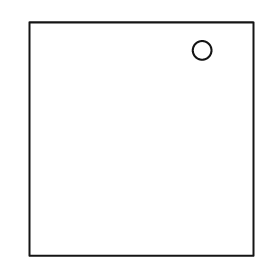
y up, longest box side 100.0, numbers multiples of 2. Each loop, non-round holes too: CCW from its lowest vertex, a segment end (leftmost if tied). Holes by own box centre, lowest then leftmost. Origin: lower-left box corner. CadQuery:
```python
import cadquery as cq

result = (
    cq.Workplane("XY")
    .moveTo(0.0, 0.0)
    .lineTo(96.0, 0.0)
    .lineTo(96.0, 100.0)
    .lineTo(0.0, 100.0)
    .close()
    .moveTo(74.0, 88.0)
    .circle(4.0)
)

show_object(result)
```